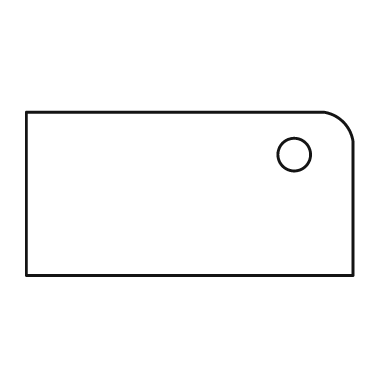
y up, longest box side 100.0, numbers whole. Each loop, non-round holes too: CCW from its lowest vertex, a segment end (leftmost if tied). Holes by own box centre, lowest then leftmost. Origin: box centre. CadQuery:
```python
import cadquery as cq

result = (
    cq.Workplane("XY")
    .moveTo(-50.0, -25.0)
    .lineTo(50.0, -25.0)
    .lineTo(50.0, 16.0)
    .threePointArc((47.0, 22.0), (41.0, 25.0))
    .lineTo(-50.0, 25.0)
    .close()
    .moveTo(32.0, 12.0)
    .circle(5.0)
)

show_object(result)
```